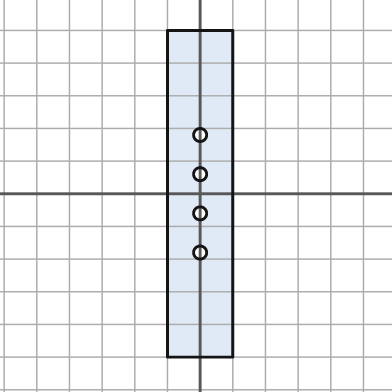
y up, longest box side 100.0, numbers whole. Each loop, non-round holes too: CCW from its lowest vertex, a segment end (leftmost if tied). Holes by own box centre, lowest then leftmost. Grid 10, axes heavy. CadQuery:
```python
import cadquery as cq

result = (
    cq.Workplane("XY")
    .moveTo(-10.0, -50.0)
    .lineTo(10.0, -50.0)
    .lineTo(10.0, 50.0)
    .lineTo(-10.0, 50.0)
    .close()
    .moveTo(0.0, -18.0)
    .circle(2.0)
    .moveTo(0.0, -6.0)
    .circle(2.0)
    .moveTo(0.0, 6.0)
    .circle(2.0)
    .moveTo(0.0, 18.0)
    .circle(2.0)
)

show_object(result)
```